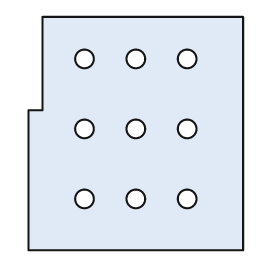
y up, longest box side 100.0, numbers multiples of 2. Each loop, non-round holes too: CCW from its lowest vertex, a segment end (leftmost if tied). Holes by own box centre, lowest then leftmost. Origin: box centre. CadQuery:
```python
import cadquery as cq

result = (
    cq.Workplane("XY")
    .moveTo(-46.0, -50.0)
    .lineTo(46.0, -50.0)
    .lineTo(46.0, 50.0)
    .lineTo(-40.0, 50.0)
    .lineTo(-40.0, 10.0)
    .lineTo(-46.0, 10.0)
    .close()
    .moveTo(-22.0, -28.0)
    .circle(4.0)
    .moveTo(0.0, -28.0)
    .circle(4.0)
    .moveTo(22.0, -28.0)
    .circle(4.0)
    .moveTo(-22.0, 2.0)
    .circle(4.0)
    .moveTo(0.0, 2.0)
    .circle(4.0)
    .moveTo(22.0, 2.0)
    .circle(4.0)
    .moveTo(-22.0, 32.0)
    .circle(4.0)
    .moveTo(0.0, 32.0)
    .circle(4.0)
    .moveTo(22.0, 32.0)
    .circle(4.0)
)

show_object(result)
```